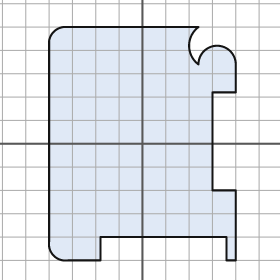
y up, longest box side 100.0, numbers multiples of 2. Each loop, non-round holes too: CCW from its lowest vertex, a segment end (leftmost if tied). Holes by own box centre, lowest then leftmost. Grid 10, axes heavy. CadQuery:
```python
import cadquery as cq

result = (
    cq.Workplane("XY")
    .moveTo(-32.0, -50.0)
    .lineTo(-18.0, -50.0)
    .lineTo(-18.0, -40.0)
    .lineTo(36.0, -40.0)
    .lineTo(36.0, -50.0)
    .lineTo(40.0, -50.0)
    .lineTo(40.0, -20.0)
    .lineTo(30.0, -20.0)
    .lineTo(30.0, 22.0)
    .lineTo(40.0, 22.0)
    .lineTo(40.0, 34.0)
    .threePointArc((32.0, 42.0), (24.0, 34.0))
    .threePointArc((20.0, 42.0), (24.0, 50.0))
    .lineTo(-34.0, 50.0)
    .threePointArc((-38.0, 48.0), (-40.0, 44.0))
    .lineTo(-40.0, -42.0)
    .threePointArc((-38.0, -48.0), (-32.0, -50.0))
    .close()
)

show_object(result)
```